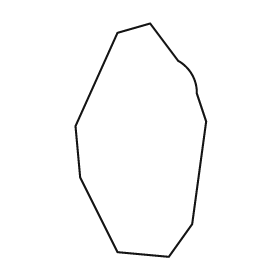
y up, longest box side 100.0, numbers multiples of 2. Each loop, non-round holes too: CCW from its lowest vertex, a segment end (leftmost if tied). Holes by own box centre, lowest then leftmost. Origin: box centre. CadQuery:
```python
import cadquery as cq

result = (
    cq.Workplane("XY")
    .moveTo(12.0, -50.0)
    .lineTo(22.0, -36.0)
    .lineTo(28.0, 8.0)
    .lineTo(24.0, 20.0)
    .threePointArc((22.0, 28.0), (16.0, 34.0))
    .lineTo(4.0, 50.0)
    .lineTo(-10.0, 46.0)
    .lineTo(-28.0, 6.0)
    .lineTo(-26.0, -16.0)
    .lineTo(-10.0, -48.0)
    .close()
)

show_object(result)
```